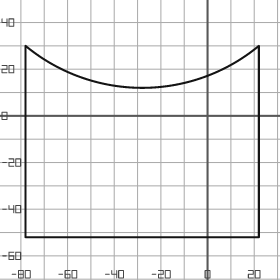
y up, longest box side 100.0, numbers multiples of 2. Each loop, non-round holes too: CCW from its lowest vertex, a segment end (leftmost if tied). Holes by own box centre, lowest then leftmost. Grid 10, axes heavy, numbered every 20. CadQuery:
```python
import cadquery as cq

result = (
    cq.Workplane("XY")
    .moveTo(-78.0, -52.0)
    .lineTo(22.0, -52.0)
    .lineTo(22.0, 30.0)
    .threePointArc((-28.0, 12.0), (-78.0, 30.0))
    .close()
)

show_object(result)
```